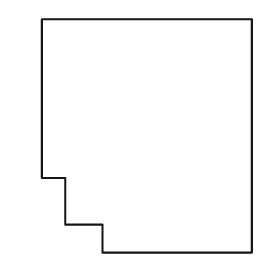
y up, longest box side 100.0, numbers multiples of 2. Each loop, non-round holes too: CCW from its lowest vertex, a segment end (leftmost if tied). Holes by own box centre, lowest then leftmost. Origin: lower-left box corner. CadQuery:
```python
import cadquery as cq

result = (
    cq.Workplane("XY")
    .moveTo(26.0, 0.0)
    .lineTo(90.0, 0.0)
    .lineTo(90.0, 100.0)
    .lineTo(0.0, 100.0)
    .lineTo(0.0, 32.0)
    .lineTo(10.0, 32.0)
    .lineTo(10.0, 12.0)
    .lineTo(26.0, 12.0)
    .close()
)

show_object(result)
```